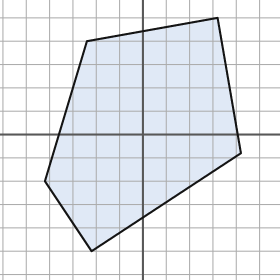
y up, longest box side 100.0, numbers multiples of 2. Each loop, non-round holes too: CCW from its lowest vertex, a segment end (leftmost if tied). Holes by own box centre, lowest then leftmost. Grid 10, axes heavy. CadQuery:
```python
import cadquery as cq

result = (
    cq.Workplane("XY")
    .moveTo(-22.0, -50.0)
    .lineTo(42.0, -8.0)
    .lineTo(32.0, 50.0)
    .lineTo(-24.0, 40.0)
    .lineTo(-42.0, -20.0)
    .close()
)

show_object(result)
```